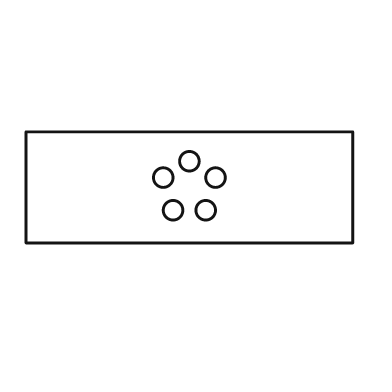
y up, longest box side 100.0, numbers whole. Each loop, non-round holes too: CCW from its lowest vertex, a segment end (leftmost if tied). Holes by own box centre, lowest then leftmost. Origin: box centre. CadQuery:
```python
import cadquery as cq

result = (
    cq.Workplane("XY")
    .moveTo(-50.0, -17.0)
    .lineTo(50.0, -17.0)
    .lineTo(50.0, 17.0)
    .lineTo(-50.0, 17.0)
    .close()
    .moveTo(-5.0, -7.0)
    .circle(3.0)
    .moveTo(5.0, -7.0)
    .circle(3.0)
    .moveTo(-8.0, 3.0)
    .circle(3.0)
    .moveTo(8.0, 3.0)
    .circle(3.0)
    .moveTo(0.0, 8.0)
    .circle(3.0)
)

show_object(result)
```